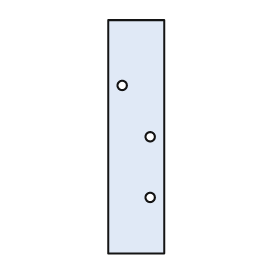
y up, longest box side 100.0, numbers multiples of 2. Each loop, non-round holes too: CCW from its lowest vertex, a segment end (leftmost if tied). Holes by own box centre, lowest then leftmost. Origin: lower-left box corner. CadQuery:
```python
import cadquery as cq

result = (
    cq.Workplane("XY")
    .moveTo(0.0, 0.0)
    .lineTo(24.0, 0.0)
    .lineTo(24.0, 100.0)
    .lineTo(0.0, 100.0)
    .close()
    .moveTo(18.0, 24.0)
    .circle(2.0)
    .moveTo(18.0, 50.0)
    .circle(2.0)
    .moveTo(6.0, 72.0)
    .circle(2.0)
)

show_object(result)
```